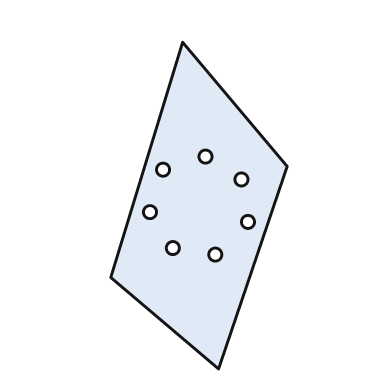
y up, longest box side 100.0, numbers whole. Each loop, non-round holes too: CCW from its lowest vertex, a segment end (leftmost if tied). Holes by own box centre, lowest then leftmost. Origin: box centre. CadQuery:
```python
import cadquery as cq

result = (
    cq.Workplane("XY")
    .moveTo(6.0, -50.0)
    .lineTo(27.0, 12.0)
    .lineTo(-5.0, 50.0)
    .lineTo(-27.0, -22.0)
    .close()
    .moveTo(5.0, -15.0)
    .circle(2.0)
    .moveTo(-8.0, -13.0)
    .circle(2.0)
    .moveTo(15.0, -5.0)
    .circle(2.0)
    .moveTo(-15.0, -2.0)
    .circle(2.0)
    .moveTo(13.0, 8.0)
    .circle(2.0)
    .moveTo(-11.0, 11.0)
    .circle(2.0)
    .moveTo(2.0, 15.0)
    .circle(2.0)
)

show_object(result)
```